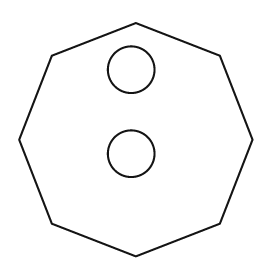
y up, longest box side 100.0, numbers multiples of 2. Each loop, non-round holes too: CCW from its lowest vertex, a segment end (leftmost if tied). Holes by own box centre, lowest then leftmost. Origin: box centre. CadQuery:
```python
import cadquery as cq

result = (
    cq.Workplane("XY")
    .moveTo(0.0, -50.0)
    .lineTo(36.0, -36.0)
    .lineTo(50.0, 0.0)
    .lineTo(36.0, 36.0)
    .lineTo(0.0, 50.0)
    .lineTo(-36.0, 36.0)
    .lineTo(-50.0, 0.0)
    .lineTo(-36.0, -36.0)
    .close()
    .moveTo(-2.0, -6.0)
    .circle(10.0)
    .moveTo(-2.0, 30.0)
    .circle(10.0)
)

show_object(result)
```